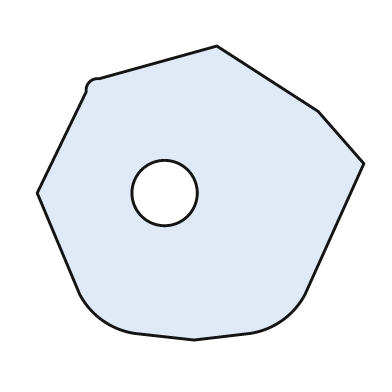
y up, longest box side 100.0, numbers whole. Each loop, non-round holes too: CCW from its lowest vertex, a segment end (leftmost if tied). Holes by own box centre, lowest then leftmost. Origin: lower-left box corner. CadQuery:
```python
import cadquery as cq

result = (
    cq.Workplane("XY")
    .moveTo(48.0, 0.0)
    .lineTo(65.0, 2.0)
    .threePointArc((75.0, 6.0), (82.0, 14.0))
    .lineTo(100.0, 54.0)
    .lineTo(86.0, 70.0)
    .lineTo(55.0, 90.0)
    .lineTo(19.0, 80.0)
    .threePointArc((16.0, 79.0), (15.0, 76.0))
    .lineTo(0.0, 45.0)
    .lineTo(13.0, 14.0)
    .threePointArc((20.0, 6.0), (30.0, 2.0))
    .close()
    .moveTo(39.0, 45.0)
    .circle(10.0)
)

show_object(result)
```